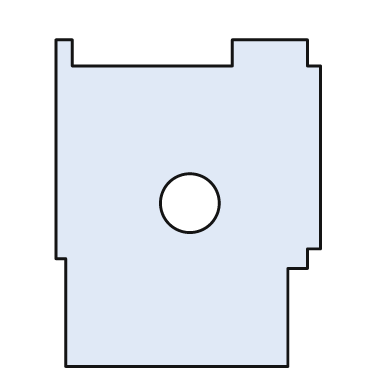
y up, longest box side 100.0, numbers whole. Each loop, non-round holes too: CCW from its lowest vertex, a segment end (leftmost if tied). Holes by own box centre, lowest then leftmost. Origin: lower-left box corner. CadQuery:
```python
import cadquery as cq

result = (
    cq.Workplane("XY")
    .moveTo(3.0, 0.0)
    .lineTo(71.0, 0.0)
    .lineTo(71.0, 30.0)
    .lineTo(77.0, 30.0)
    .lineTo(77.0, 36.0)
    .lineTo(81.0, 36.0)
    .lineTo(81.0, 92.0)
    .lineTo(77.0, 92.0)
    .lineTo(77.0, 100.0)
    .lineTo(54.0, 100.0)
    .lineTo(54.0, 92.0)
    .lineTo(5.0, 92.0)
    .lineTo(5.0, 100.0)
    .lineTo(0.0, 100.0)
    .lineTo(0.0, 33.0)
    .lineTo(3.0, 33.0)
    .close()
    .moveTo(41.0, 50.0)
    .circle(9.0)
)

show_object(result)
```